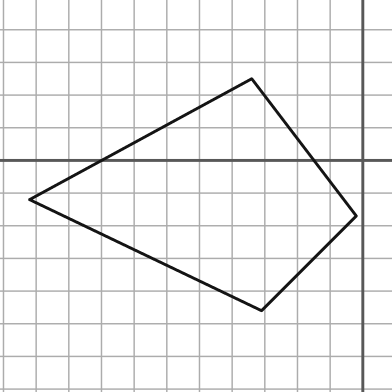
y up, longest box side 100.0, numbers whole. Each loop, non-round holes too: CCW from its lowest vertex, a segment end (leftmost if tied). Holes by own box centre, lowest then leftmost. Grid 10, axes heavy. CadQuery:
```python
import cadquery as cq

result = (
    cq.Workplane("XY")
    .moveTo(-31.0, -46.0)
    .lineTo(-2.0, -17.0)
    .lineTo(-34.0, 25.0)
    .lineTo(-102.0, -12.0)
    .close()
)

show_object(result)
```